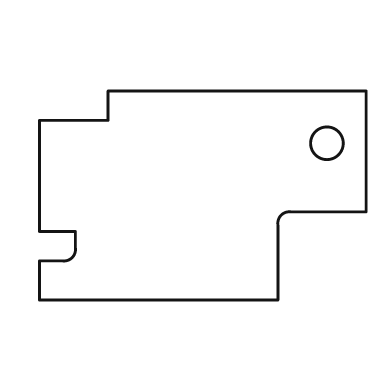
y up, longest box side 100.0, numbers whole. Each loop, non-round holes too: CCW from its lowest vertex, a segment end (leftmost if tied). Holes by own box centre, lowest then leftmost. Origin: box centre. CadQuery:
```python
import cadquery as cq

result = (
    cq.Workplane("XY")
    .moveTo(-50.0, -32.0)
    .lineTo(23.0, -32.0)
    .lineTo(23.0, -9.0)
    .threePointArc((24.0, -6.0), (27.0, -5.0))
    .lineTo(50.0, -5.0)
    .lineTo(50.0, 32.0)
    .lineTo(-29.0, 32.0)
    .lineTo(-29.0, 23.0)
    .lineTo(-50.0, 23.0)
    .lineTo(-50.0, -11.0)
    .lineTo(-39.0, -11.0)
    .lineTo(-39.0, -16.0)
    .threePointArc((-40.0, -19.0), (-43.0, -20.0))
    .lineTo(-50.0, -20.0)
    .close()
    .moveTo(38.0, 16.0)
    .circle(5.0)
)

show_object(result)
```